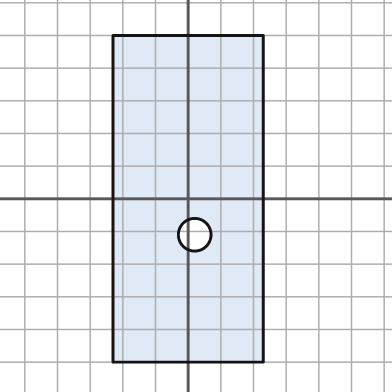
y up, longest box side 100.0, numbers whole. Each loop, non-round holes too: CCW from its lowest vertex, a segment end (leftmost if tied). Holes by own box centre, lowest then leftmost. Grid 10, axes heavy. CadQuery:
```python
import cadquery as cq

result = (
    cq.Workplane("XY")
    .moveTo(-23.0, -50.0)
    .lineTo(23.0, -50.0)
    .lineTo(23.0, 50.0)
    .lineTo(-23.0, 50.0)
    .close()
    .moveTo(2.0, -11.0)
    .circle(5.0)
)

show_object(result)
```